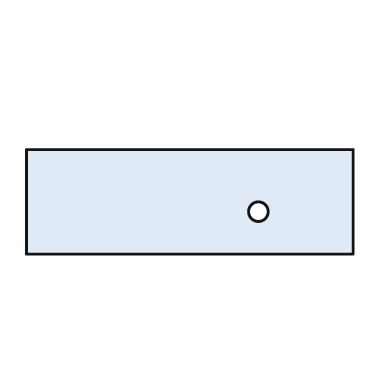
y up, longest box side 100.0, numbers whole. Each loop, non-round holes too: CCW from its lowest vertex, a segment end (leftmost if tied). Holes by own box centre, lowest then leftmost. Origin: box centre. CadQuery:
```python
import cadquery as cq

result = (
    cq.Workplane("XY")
    .moveTo(-50.0, -16.0)
    .lineTo(50.0, -16.0)
    .lineTo(50.0, 16.0)
    .lineTo(-50.0, 16.0)
    .close()
    .moveTo(21.0, -3.0)
    .circle(3.0)
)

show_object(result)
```